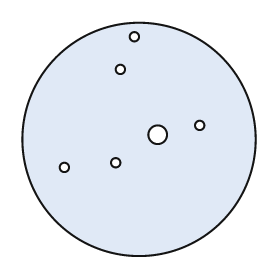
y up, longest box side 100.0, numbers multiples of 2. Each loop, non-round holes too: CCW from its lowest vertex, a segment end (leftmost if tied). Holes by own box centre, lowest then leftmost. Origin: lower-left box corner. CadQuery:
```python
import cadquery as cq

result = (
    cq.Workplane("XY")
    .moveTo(50.0, 50.0)
    .circle(50.0)
    .moveTo(18.0, 38.0)
    .circle(2.0)
    .moveTo(40.0, 40.0)
    .circle(2.0)
    .moveTo(58.0, 52.0)
    .circle(4.0)
    .moveTo(76.0, 56.0)
    .circle(2.0)
    .moveTo(42.0, 80.0)
    .circle(2.0)
    .moveTo(48.0, 94.0)
    .circle(2.0)
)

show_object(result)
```